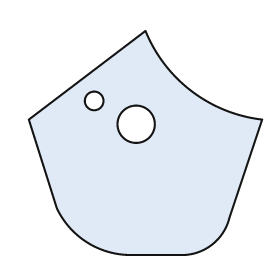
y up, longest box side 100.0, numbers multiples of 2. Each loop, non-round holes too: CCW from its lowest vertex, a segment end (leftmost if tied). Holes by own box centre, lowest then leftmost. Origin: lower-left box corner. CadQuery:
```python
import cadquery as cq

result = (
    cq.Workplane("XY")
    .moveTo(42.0, 0.0)
    .lineTo(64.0, 0.0)
    .threePointArc((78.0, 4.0), (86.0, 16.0))
    .lineTo(100.0, 58.0)
    .threePointArc((70.0, 70.0), (50.0, 96.0))
    .lineTo(0.0, 58.0)
    .lineTo(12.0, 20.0)
    .threePointArc((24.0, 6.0), (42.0, 0.0))
    .close()
    .moveTo(46.0, 56.0)
    .circle(8.0)
    .moveTo(28.0, 66.0)
    .circle(4.0)
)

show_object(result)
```